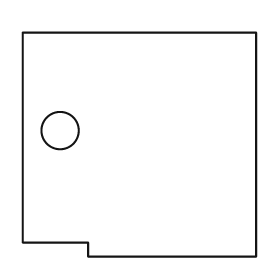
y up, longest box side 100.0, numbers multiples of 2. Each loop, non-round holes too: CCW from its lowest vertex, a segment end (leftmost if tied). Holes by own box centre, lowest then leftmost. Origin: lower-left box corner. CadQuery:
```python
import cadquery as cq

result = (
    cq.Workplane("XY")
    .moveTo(28.0, 0.0)
    .lineTo(100.0, 0.0)
    .lineTo(100.0, 96.0)
    .lineTo(0.0, 96.0)
    .lineTo(0.0, 6.0)
    .lineTo(28.0, 6.0)
    .close()
    .moveTo(16.0, 54.0)
    .circle(8.0)
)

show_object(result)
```